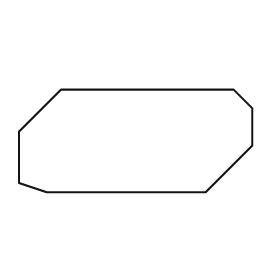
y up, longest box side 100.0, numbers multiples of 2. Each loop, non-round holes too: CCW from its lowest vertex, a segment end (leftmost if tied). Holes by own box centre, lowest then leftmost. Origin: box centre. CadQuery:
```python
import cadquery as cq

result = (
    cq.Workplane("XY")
    .moveTo(-38.0, -22.0)
    .lineTo(30.0, -22.0)
    .lineTo(50.0, -2.0)
    .lineTo(50.0, 14.0)
    .lineTo(42.0, 22.0)
    .lineTo(-32.0, 22.0)
    .lineTo(-50.0, 4.0)
    .lineTo(-50.0, -18.0)
    .close()
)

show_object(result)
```